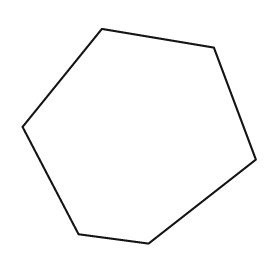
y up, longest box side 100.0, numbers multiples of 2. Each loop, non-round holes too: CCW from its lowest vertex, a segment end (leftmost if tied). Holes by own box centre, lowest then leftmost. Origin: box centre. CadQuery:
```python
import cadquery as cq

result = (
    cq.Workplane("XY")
    .moveTo(4.0, -46.0)
    .lineTo(50.0, -10.0)
    .lineTo(32.0, 38.0)
    .lineTo(-16.0, 46.0)
    .lineTo(-50.0, 4.0)
    .lineTo(-26.0, -42.0)
    .close()
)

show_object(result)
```